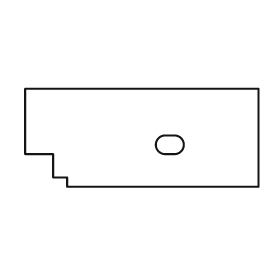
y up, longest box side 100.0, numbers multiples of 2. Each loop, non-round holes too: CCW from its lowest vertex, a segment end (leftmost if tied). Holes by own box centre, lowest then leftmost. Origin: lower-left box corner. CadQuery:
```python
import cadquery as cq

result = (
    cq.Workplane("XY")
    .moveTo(18.0, 0.0)
    .lineTo(100.0, 0.0)
    .lineTo(100.0, 42.0)
    .lineTo(0.0, 42.0)
    .lineTo(0.0, 14.0)
    .lineTo(12.0, 14.0)
    .lineTo(12.0, 4.0)
    .lineTo(18.0, 4.0)
    .close()
    .moveTo(60.0, 14.0)
    .lineTo(64.0, 14.0)
    .threePointArc((68.0, 18.0), (64.0, 22.0))
    .lineTo(60.0, 22.0)
    .threePointArc((56.0, 18.0), (60.0, 14.0))
    .close()
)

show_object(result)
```